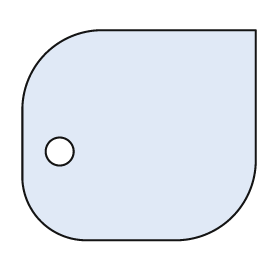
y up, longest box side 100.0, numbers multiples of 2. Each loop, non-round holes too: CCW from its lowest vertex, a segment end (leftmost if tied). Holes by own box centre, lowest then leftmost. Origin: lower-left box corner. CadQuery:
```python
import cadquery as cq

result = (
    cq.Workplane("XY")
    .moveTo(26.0, 0.0)
    .lineTo(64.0, 0.0)
    .threePointArc((90.0, 10.0), (100.0, 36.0))
    .lineTo(100.0, 90.0)
    .lineTo(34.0, 90.0)
    .threePointArc((10.0, 80.0), (0.0, 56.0))
    .lineTo(0.0, 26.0)
    .threePointArc((8.0, 8.0), (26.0, 0.0))
    .close()
    .moveTo(16.0, 38.0)
    .circle(6.0)
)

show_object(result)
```